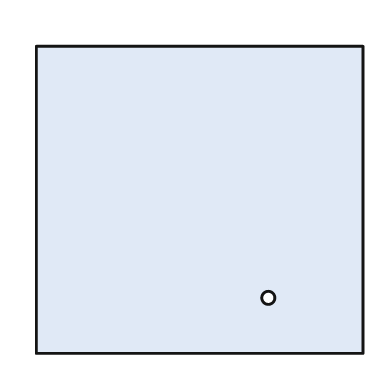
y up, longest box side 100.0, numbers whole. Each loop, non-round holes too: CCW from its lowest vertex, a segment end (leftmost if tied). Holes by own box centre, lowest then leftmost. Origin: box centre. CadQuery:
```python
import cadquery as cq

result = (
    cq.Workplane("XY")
    .moveTo(-50.0, -47.0)
    .lineTo(50.0, -47.0)
    .lineTo(50.0, 47.0)
    .lineTo(-50.0, 47.0)
    .close()
    .moveTo(21.0, -30.0)
    .circle(2.0)
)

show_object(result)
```